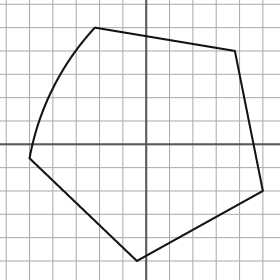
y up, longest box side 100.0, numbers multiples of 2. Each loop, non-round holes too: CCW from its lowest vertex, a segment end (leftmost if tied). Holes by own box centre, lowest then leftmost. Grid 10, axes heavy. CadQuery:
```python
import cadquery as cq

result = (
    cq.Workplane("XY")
    .moveTo(-4.0, -50.0)
    .lineTo(50.0, -20.0)
    .lineTo(38.0, 40.0)
    .lineTo(-22.0, 50.0)
    .threePointArc((-40.0, 24.0), (-50.0, -6.0))
    .close()
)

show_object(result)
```